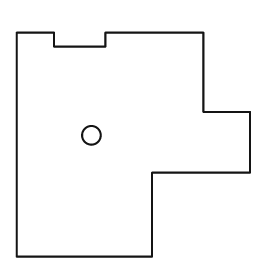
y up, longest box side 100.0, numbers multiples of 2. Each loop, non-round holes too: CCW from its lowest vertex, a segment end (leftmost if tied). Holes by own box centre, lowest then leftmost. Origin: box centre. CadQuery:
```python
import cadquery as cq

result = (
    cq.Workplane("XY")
    .moveTo(-50.0, -48.0)
    .lineTo(8.0, -48.0)
    .lineTo(8.0, -12.0)
    .lineTo(50.0, -12.0)
    .lineTo(50.0, 14.0)
    .lineTo(30.0, 14.0)
    .lineTo(30.0, 48.0)
    .lineTo(-12.0, 48.0)
    .lineTo(-12.0, 42.0)
    .lineTo(-34.0, 42.0)
    .lineTo(-34.0, 48.0)
    .lineTo(-50.0, 48.0)
    .close()
    .moveTo(-18.0, 4.0)
    .circle(4.0)
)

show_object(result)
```